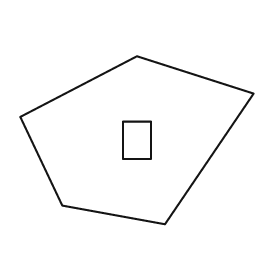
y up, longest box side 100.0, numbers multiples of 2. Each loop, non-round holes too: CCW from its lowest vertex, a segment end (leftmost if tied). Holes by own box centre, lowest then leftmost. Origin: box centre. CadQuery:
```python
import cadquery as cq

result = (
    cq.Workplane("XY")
    .moveTo(12.0, -36.0)
    .lineTo(50.0, 20.0)
    .lineTo(0.0, 36.0)
    .lineTo(-50.0, 10.0)
    .lineTo(-32.0, -28.0)
    .close()
    .moveTo(-6.0, -8.0)
    .lineTo(6.0, -8.0)
    .lineTo(6.0, 8.0)
    .lineTo(-6.0, 8.0)
    .close()
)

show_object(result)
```